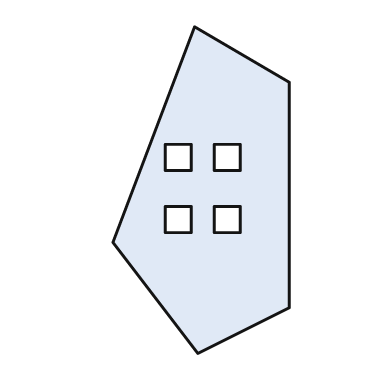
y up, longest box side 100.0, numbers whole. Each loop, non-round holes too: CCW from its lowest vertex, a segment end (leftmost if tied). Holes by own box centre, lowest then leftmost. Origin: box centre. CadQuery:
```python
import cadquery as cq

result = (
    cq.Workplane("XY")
    .moveTo(-1.0, -50.0)
    .lineTo(27.0, -36.0)
    .lineTo(27.0, 33.0)
    .lineTo(-2.0, 50.0)
    .lineTo(-27.0, -16.0)
    .close()
    .moveTo(-11.0, -13.0)
    .lineTo(-3.0, -13.0)
    .lineTo(-3.0, -5.0)
    .lineTo(-11.0, -5.0)
    .close()
    .moveTo(4.0, -13.0)
    .lineTo(12.0, -13.0)
    .lineTo(12.0, -5.0)
    .lineTo(4.0, -5.0)
    .close()
    .moveTo(-11.0, 6.0)
    .lineTo(-3.0, 6.0)
    .lineTo(-3.0, 14.0)
    .lineTo(-11.0, 14.0)
    .close()
    .moveTo(4.0, 6.0)
    .lineTo(12.0, 6.0)
    .lineTo(12.0, 14.0)
    .lineTo(4.0, 14.0)
    .close()
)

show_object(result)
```